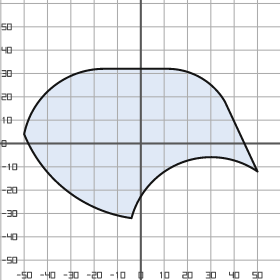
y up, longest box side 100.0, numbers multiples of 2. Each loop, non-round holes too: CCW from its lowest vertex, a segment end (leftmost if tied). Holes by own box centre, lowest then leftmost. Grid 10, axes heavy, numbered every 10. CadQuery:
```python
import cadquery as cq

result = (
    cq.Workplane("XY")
    .moveTo(-4.0, -32.0)
    .threePointArc((18.0, -8.0), (50.0, -12.0))
    .lineTo(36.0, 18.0)
    .threePointArc((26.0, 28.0), (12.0, 32.0))
    .lineTo(-16.0, 32.0)
    .threePointArc((-38.0, 24.0), (-50.0, 4.0))
    .threePointArc((-32.0, -20.0), (-4.0, -32.0))
    .close()
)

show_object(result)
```